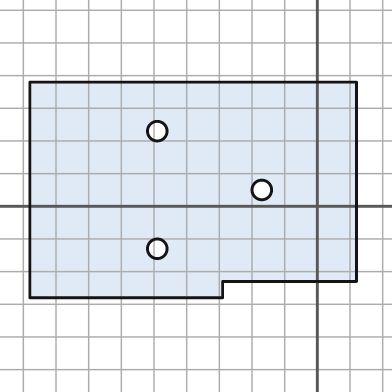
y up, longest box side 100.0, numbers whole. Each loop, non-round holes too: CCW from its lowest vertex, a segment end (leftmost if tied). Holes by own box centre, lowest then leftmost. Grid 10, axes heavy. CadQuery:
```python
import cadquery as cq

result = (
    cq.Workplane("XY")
    .moveTo(-88.0, -28.0)
    .lineTo(-29.0, -28.0)
    .lineTo(-29.0, -23.0)
    .lineTo(12.0, -23.0)
    .lineTo(12.0, 38.0)
    .lineTo(-88.0, 38.0)
    .close()
    .moveTo(-49.0, -13.0)
    .circle(3.0)
    .moveTo(-17.0, 5.0)
    .circle(3.0)
    .moveTo(-49.0, 23.0)
    .circle(3.0)
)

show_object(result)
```